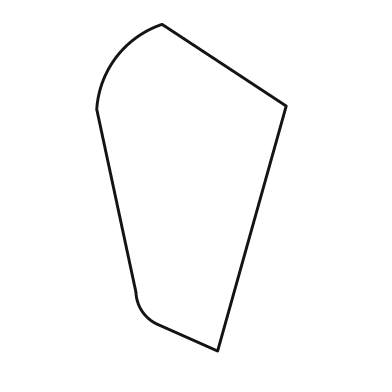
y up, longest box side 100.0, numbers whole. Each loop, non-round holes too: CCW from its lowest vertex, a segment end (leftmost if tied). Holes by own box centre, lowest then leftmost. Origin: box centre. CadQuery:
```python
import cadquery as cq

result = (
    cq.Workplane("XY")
    .moveTo(8.0, -50.0)
    .lineTo(29.0, 25.0)
    .lineTo(-9.0, 50.0)
    .threePointArc((-23.0, 40.0), (-29.0, 24.0))
    .lineTo(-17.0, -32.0)
    .threePointArc((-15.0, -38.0), (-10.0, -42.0))
    .close()
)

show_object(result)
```